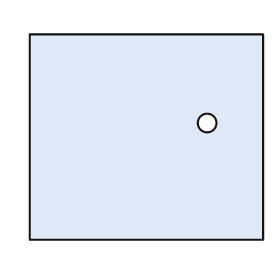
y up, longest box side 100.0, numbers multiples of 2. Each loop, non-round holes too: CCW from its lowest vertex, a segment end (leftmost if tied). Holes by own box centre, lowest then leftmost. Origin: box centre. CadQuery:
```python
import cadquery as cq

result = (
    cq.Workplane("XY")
    .moveTo(-50.0, -44.0)
    .lineTo(50.0, -44.0)
    .lineTo(50.0, 44.0)
    .lineTo(-50.0, 44.0)
    .close()
    .moveTo(26.0, 6.0)
    .circle(4.0)
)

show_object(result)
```